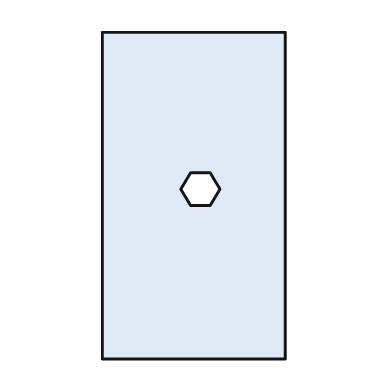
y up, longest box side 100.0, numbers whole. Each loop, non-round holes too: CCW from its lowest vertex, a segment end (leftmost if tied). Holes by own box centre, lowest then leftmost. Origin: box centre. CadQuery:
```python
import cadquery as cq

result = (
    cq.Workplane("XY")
    .moveTo(-28.0, -50.0)
    .lineTo(28.0, -50.0)
    .lineTo(28.0, 50.0)
    .lineTo(-28.0, 50.0)
    .close()
    .moveTo(-1.0, -3.0)
    .lineTo(5.0, -3.0)
    .lineTo(8.0, 2.0)
    .lineTo(5.0, 7.0)
    .lineTo(-1.0, 7.0)
    .lineTo(-4.0, 2.0)
    .close()
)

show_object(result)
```